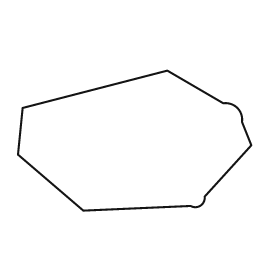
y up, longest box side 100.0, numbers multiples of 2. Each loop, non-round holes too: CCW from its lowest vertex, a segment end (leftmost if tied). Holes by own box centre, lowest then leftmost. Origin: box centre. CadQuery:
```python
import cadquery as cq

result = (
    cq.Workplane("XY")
    .moveTo(-22.0, -30.0)
    .lineTo(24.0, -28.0)
    .threePointArc((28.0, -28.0), (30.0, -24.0))
    .lineTo(50.0, -2.0)
    .lineTo(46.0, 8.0)
    .threePointArc((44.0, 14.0), (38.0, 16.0))
    .lineTo(14.0, 30.0)
    .lineTo(-48.0, 14.0)
    .lineTo(-50.0, -6.0)
    .close()
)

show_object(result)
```